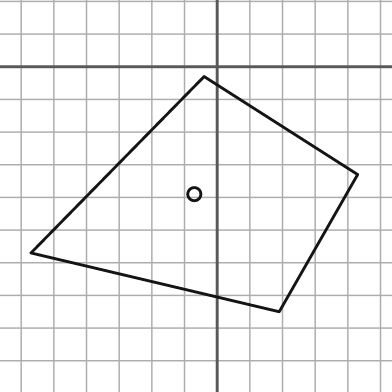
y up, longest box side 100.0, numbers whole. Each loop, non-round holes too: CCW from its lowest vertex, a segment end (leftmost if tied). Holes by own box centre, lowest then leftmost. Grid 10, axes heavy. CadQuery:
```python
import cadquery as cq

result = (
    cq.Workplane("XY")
    .moveTo(19.0, -75.0)
    .lineTo(43.0, -33.0)
    .lineTo(-4.0, -3.0)
    .lineTo(-57.0, -57.0)
    .close()
    .moveTo(-7.0, -39.0)
    .circle(2.0)
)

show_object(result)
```